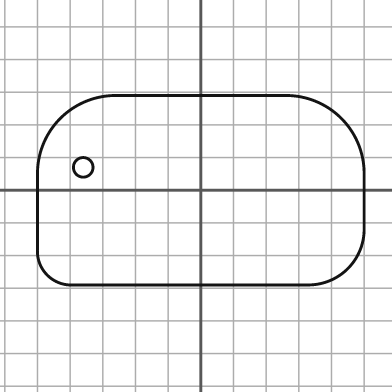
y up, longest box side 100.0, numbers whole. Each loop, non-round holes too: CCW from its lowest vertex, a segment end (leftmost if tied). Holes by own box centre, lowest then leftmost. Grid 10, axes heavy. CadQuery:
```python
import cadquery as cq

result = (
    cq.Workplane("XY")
    .moveTo(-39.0, -29.0)
    .lineTo(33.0, -29.0)
    .threePointArc((45.0, -24.0), (50.0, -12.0))
    .lineTo(50.0, 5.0)
    .threePointArc((43.0, 22.0), (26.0, 29.0))
    .lineTo(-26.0, 29.0)
    .threePointArc((-43.0, 22.0), (-50.0, 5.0))
    .lineTo(-50.0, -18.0)
    .threePointArc((-47.0, -26.0), (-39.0, -29.0))
    .close()
    .moveTo(-36.0, 7.0)
    .circle(3.0)
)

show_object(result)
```